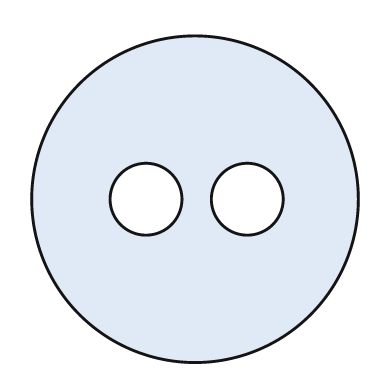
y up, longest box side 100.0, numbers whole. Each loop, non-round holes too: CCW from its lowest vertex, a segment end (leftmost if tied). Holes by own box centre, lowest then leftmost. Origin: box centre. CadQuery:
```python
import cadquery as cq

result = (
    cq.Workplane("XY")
    .moveTo(0.0, 0.0)
    .circle(50.0)
    .moveTo(-15.0, 0.0)
    .circle(11.0)
    .moveTo(16.0, 0.0)
    .circle(11.0)
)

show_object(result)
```